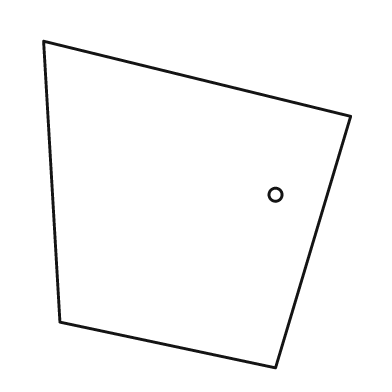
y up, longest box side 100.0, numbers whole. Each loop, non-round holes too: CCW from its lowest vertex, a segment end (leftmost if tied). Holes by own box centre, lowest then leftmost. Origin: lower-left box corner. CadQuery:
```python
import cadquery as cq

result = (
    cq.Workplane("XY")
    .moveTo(71.0, 0.0)
    .lineTo(94.0, 77.0)
    .lineTo(0.0, 100.0)
    .lineTo(5.0, 14.0)
    .close()
    .moveTo(71.0, 53.0)
    .circle(2.0)
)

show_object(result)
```